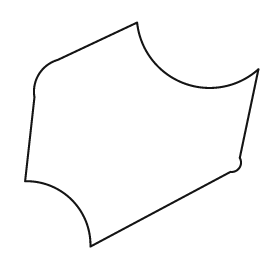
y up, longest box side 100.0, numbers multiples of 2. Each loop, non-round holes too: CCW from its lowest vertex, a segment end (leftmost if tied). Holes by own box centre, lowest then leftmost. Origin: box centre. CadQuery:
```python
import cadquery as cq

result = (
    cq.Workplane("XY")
    .moveTo(-22.0, -48.0)
    .lineTo(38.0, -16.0)
    .threePointArc((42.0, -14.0), (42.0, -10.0))
    .lineTo(50.0, 28.0)
    .threePointArc((18.0, 22.0), (-2.0, 48.0))
    .lineTo(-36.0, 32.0)
    .threePointArc((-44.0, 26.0), (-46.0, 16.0))
    .lineTo(-50.0, -20.0)
    .threePointArc((-30.0, -28.0), (-22.0, -48.0))
    .close()
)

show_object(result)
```